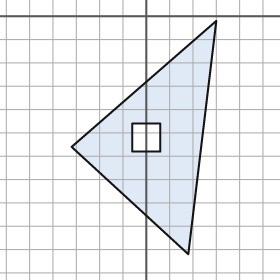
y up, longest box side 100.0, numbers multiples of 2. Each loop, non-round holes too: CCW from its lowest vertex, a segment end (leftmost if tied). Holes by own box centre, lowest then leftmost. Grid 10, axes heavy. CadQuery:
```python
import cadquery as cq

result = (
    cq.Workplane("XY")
    .moveTo(18.0, -102.0)
    .lineTo(30.0, -2.0)
    .lineTo(-32.0, -56.0)
    .close()
    .moveTo(-6.0, -58.0)
    .lineTo(6.0, -58.0)
    .lineTo(6.0, -46.0)
    .lineTo(-6.0, -46.0)
    .close()
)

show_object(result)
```